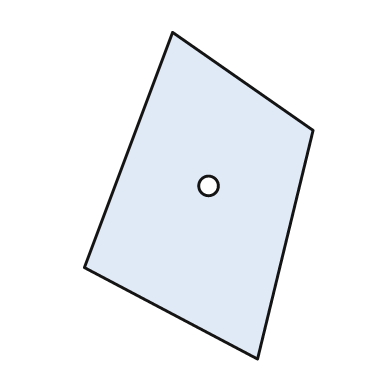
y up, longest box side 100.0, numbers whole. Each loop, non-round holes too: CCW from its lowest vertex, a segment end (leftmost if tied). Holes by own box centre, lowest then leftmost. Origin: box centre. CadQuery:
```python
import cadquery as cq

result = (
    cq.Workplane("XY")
    .moveTo(18.0, -50.0)
    .lineTo(35.0, 20.0)
    .lineTo(-8.0, 50.0)
    .lineTo(-35.0, -22.0)
    .close()
    .moveTo(3.0, 3.0)
    .circle(3.0)
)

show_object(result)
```